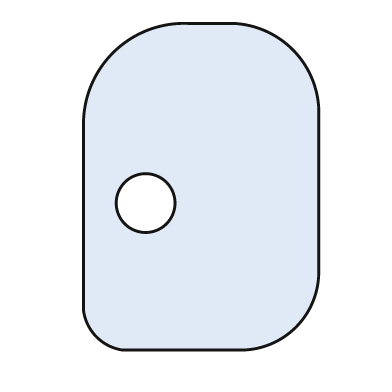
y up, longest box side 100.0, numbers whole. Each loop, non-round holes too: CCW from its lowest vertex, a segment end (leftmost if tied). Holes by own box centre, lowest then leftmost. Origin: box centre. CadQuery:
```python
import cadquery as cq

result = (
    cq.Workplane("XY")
    .moveTo(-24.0, -50.0)
    .lineTo(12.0, -50.0)
    .threePointArc((29.0, -43.0), (36.0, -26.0))
    .lineTo(36.0, 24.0)
    .threePointArc((28.0, 42.0), (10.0, 50.0))
    .lineTo(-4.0, 50.0)
    .threePointArc((-27.0, 41.0), (-36.0, 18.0))
    .lineTo(-36.0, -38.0)
    .threePointArc((-32.0, -46.0), (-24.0, -50.0))
    .close()
    .moveTo(-17.0, -5.0)
    .circle(9.0)
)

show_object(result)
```